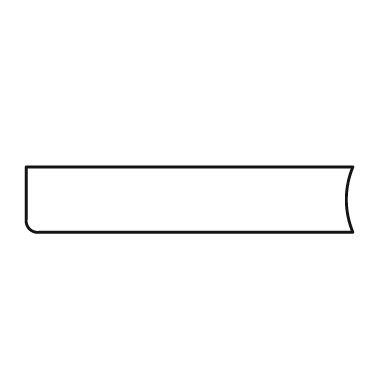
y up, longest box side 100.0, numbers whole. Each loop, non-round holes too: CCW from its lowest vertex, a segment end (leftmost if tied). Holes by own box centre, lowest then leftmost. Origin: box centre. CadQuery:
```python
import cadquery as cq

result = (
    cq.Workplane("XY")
    .moveTo(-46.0, -10.0)
    .lineTo(50.0, -10.0)
    .threePointArc((48.0, 0.0), (50.0, 10.0))
    .lineTo(-50.0, 10.0)
    .lineTo(-50.0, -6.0)
    .threePointArc((-49.0, -9.0), (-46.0, -10.0))
    .close()
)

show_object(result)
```